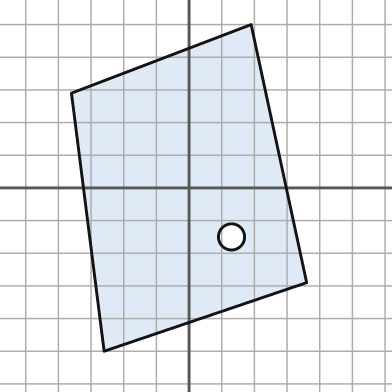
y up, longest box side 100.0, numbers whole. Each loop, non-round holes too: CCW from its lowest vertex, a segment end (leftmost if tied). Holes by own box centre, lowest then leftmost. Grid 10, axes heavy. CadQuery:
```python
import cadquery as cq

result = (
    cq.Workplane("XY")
    .moveTo(-26.0, -50.0)
    .lineTo(36.0, -29.0)
    .lineTo(19.0, 50.0)
    .lineTo(-36.0, 29.0)
    .close()
    .moveTo(13.0, -15.0)
    .circle(4.0)
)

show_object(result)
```